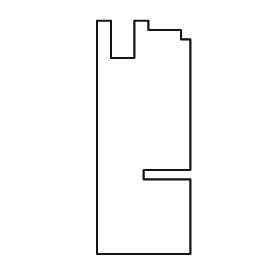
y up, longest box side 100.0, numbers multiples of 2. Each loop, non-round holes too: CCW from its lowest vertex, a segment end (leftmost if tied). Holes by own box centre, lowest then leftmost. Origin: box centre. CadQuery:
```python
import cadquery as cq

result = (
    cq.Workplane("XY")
    .moveTo(-20.0, -50.0)
    .lineTo(20.0, -50.0)
    .lineTo(20.0, -18.0)
    .lineTo(0.0, -18.0)
    .lineTo(0.0, -14.0)
    .lineTo(20.0, -14.0)
    .lineTo(20.0, 42.0)
    .lineTo(16.0, 42.0)
    .lineTo(16.0, 46.0)
    .lineTo(2.0, 46.0)
    .lineTo(2.0, 50.0)
    .lineTo(-4.0, 50.0)
    .lineTo(-4.0, 34.0)
    .lineTo(-14.0, 34.0)
    .lineTo(-14.0, 50.0)
    .lineTo(-20.0, 50.0)
    .close()
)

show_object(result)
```